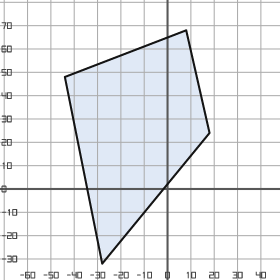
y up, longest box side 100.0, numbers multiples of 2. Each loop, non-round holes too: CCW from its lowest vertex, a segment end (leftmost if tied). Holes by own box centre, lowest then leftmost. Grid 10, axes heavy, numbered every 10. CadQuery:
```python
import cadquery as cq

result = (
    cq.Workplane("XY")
    .moveTo(-28.0, -32.0)
    .lineTo(18.0, 24.0)
    .lineTo(8.0, 68.0)
    .lineTo(-44.0, 48.0)
    .close()
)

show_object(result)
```